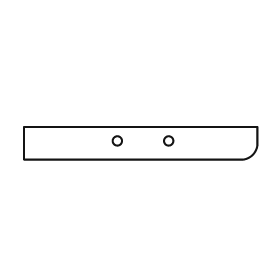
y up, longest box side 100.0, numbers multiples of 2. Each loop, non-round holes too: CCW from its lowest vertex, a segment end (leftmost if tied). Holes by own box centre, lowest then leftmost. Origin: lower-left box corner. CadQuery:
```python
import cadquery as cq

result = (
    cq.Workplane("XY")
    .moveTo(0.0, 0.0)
    .lineTo(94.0, 0.0)
    .threePointArc((98.0, 2.0), (100.0, 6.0))
    .lineTo(100.0, 14.0)
    .lineTo(0.0, 14.0)
    .close()
    .moveTo(40.0, 8.0)
    .circle(2.0)
    .moveTo(62.0, 8.0)
    .circle(2.0)
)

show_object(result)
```